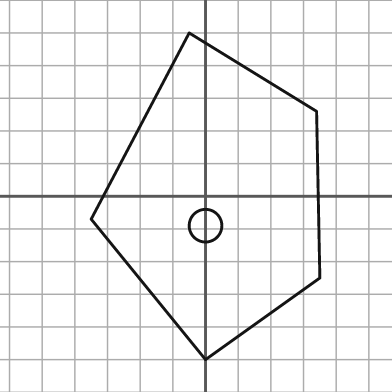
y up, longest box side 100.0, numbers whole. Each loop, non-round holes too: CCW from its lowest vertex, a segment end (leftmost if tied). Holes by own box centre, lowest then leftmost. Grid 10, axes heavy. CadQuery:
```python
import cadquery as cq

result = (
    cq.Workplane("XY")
    .moveTo(0.0, -50.0)
    .lineTo(35.0, -25.0)
    .lineTo(34.0, 26.0)
    .lineTo(-5.0, 50.0)
    .lineTo(-35.0, -7.0)
    .close()
    .moveTo(0.0, -9.0)
    .circle(5.0)
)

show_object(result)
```